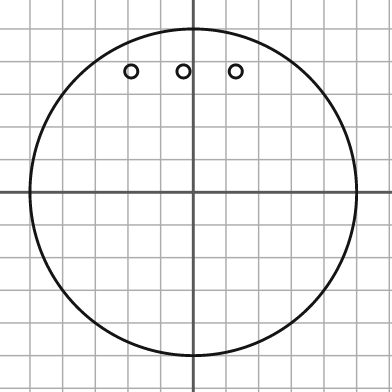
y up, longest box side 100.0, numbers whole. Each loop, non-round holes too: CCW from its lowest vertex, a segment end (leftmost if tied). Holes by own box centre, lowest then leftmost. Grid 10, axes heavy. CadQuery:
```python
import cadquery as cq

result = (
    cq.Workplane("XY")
    .moveTo(0.0, 0.0)
    .circle(50.0)
    .moveTo(-19.0, 37.0)
    .circle(2.0)
    .moveTo(-3.0, 37.0)
    .circle(2.0)
    .moveTo(13.0, 37.0)
    .circle(2.0)
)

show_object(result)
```